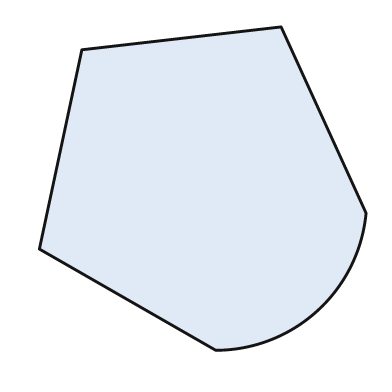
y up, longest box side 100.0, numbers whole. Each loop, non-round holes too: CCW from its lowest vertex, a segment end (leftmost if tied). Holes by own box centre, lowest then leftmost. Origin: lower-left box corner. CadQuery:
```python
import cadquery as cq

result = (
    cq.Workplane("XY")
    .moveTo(54.0, 0.0)
    .threePointArc((85.0, 12.0), (100.0, 42.0))
    .lineTo(74.0, 99.0)
    .lineTo(13.0, 92.0)
    .lineTo(0.0, 31.0)
    .close()
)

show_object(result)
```